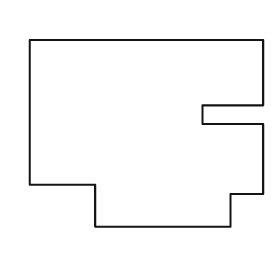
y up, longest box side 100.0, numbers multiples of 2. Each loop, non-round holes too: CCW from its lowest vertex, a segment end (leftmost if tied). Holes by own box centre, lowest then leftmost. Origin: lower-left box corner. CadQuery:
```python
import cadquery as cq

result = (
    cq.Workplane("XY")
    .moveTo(28.0, 0.0)
    .lineTo(86.0, 0.0)
    .lineTo(86.0, 14.0)
    .lineTo(100.0, 14.0)
    .lineTo(100.0, 44.0)
    .lineTo(74.0, 44.0)
    .lineTo(74.0, 52.0)
    .lineTo(100.0, 52.0)
    .lineTo(100.0, 80.0)
    .lineTo(0.0, 80.0)
    .lineTo(0.0, 18.0)
    .lineTo(28.0, 18.0)
    .close()
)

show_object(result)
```